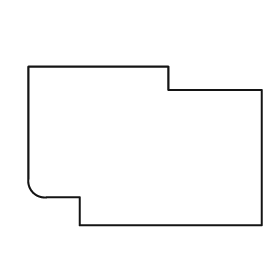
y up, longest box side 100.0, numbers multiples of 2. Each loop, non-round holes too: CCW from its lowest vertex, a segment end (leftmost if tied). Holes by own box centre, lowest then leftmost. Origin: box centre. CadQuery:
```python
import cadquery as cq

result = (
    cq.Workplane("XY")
    .moveTo(-28.0, -34.0)
    .lineTo(50.0, -34.0)
    .lineTo(50.0, 24.0)
    .lineTo(10.0, 24.0)
    .lineTo(10.0, 34.0)
    .lineTo(-50.0, 34.0)
    .lineTo(-50.0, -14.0)
    .threePointArc((-48.0, -20.0), (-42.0, -22.0))
    .lineTo(-28.0, -22.0)
    .close()
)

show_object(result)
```